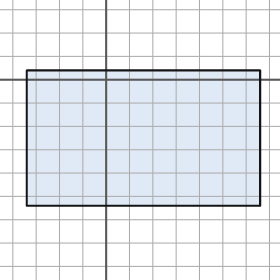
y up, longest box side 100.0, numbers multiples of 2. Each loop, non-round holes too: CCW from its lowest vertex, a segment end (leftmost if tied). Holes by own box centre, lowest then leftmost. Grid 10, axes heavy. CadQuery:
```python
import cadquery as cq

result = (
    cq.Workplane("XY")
    .moveTo(-34.0, -54.0)
    .lineTo(66.0, -54.0)
    .lineTo(66.0, 4.0)
    .lineTo(-34.0, 4.0)
    .close()
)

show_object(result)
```